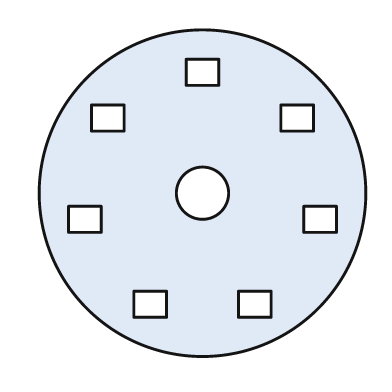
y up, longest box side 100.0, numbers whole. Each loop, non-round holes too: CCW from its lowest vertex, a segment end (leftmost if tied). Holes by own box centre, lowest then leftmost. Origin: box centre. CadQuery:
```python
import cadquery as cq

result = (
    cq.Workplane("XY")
    .moveTo(0.0, 0.0)
    .circle(50.0)
    .moveTo(-21.0, -38.0)
    .lineTo(-11.0, -38.0)
    .lineTo(-11.0, -30.0)
    .lineTo(-21.0, -30.0)
    .close()
    .moveTo(11.0, -38.0)
    .lineTo(21.0, -38.0)
    .lineTo(21.0, -30.0)
    .lineTo(11.0, -30.0)
    .close()
    .moveTo(-41.0, -12.0)
    .lineTo(-31.0, -12.0)
    .lineTo(-31.0, -4.0)
    .lineTo(-41.0, -4.0)
    .close()
    .moveTo(31.0, -12.0)
    .lineTo(41.0, -12.0)
    .lineTo(41.0, -4.0)
    .lineTo(31.0, -4.0)
    .close()
    .moveTo(0.0, 0.0)
    .circle(8.0)
    .moveTo(-34.0, 19.0)
    .lineTo(-24.0, 19.0)
    .lineTo(-24.0, 27.0)
    .lineTo(-34.0, 27.0)
    .close()
    .moveTo(24.0, 19.0)
    .lineTo(34.0, 19.0)
    .lineTo(34.0, 27.0)
    .lineTo(24.0, 27.0)
    .close()
    .moveTo(-5.0, 33.0)
    .lineTo(5.0, 33.0)
    .lineTo(5.0, 41.0)
    .lineTo(-5.0, 41.0)
    .close()
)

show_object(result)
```